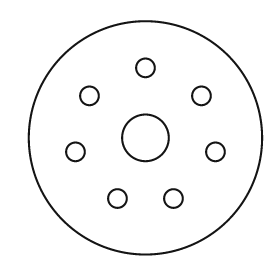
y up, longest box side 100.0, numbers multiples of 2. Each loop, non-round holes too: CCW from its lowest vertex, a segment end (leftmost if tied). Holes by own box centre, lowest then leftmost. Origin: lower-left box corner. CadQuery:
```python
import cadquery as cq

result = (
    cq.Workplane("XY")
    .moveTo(50.0, 50.0)
    .circle(50.0)
    .moveTo(38.0, 24.0)
    .circle(4.0)
    .moveTo(62.0, 24.0)
    .circle(4.0)
    .moveTo(20.0, 44.0)
    .circle(4.0)
    .moveTo(80.0, 44.0)
    .circle(4.0)
    .moveTo(50.0, 50.0)
    .circle(10.0)
    .moveTo(26.0, 68.0)
    .circle(4.0)
    .moveTo(74.0, 68.0)
    .circle(4.0)
    .moveTo(50.0, 80.0)
    .circle(4.0)
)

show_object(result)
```